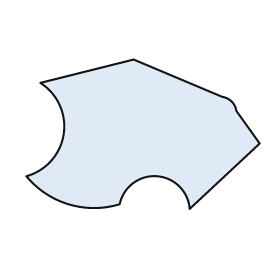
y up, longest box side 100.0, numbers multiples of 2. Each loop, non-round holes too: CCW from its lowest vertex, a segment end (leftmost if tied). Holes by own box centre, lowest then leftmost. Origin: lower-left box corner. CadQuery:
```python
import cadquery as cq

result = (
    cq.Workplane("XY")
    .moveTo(70.0, 0.0)
    .lineTo(100.0, 28.0)
    .lineTo(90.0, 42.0)
    .threePointArc((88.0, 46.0), (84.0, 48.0))
    .lineTo(46.0, 64.0)
    .lineTo(6.0, 54.0)
    .threePointArc((16.0, 32.0), (0.0, 14.0))
    .threePointArc((18.0, 2.0), (40.0, 2.0))
    .threePointArc((56.0, 14.0), (70.0, 0.0))
    .close()
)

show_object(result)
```